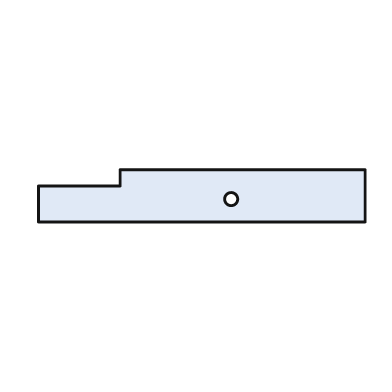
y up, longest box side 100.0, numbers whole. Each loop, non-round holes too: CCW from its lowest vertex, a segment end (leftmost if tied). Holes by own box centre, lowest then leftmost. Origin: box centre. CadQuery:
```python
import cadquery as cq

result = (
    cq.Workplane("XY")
    .moveTo(-50.0, -8.0)
    .lineTo(50.0, -8.0)
    .lineTo(50.0, 8.0)
    .lineTo(-25.0, 8.0)
    .lineTo(-25.0, 3.0)
    .lineTo(-50.0, 3.0)
    .close()
    .moveTo(9.0, -1.0)
    .circle(2.0)
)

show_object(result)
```